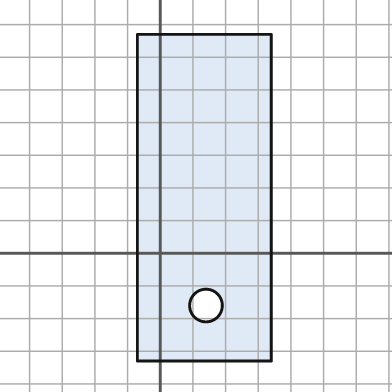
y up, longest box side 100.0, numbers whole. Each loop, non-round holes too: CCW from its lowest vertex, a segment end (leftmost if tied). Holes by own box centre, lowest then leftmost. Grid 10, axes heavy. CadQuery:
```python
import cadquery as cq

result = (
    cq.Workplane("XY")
    .moveTo(-7.0, -33.0)
    .lineTo(34.0, -33.0)
    .lineTo(34.0, 67.0)
    .lineTo(-7.0, 67.0)
    .close()
    .moveTo(14.0, -16.0)
    .circle(5.0)
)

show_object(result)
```